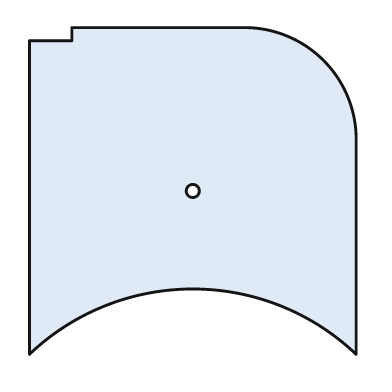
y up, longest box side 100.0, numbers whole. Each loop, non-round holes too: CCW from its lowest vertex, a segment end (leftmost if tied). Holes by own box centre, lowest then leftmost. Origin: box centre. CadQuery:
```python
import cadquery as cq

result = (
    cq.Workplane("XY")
    .moveTo(-50.0, -50.0)
    .threePointArc((0.0, -30.0), (50.0, -50.0))
    .lineTo(50.0, 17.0)
    .threePointArc((40.0, 40.0), (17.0, 50.0))
    .lineTo(-37.0, 50.0)
    .lineTo(-37.0, 46.0)
    .lineTo(-50.0, 46.0)
    .close()
    .moveTo(0.0, 0.0)
    .circle(2.0)
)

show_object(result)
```